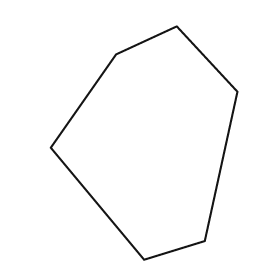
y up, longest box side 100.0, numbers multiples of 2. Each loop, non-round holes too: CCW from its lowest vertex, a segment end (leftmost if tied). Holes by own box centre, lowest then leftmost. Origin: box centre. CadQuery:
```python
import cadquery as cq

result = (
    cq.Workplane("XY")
    .moveTo(0.0, -50.0)
    .lineTo(26.0, -42.0)
    .lineTo(40.0, 22.0)
    .lineTo(14.0, 50.0)
    .lineTo(-12.0, 38.0)
    .lineTo(-40.0, -2.0)
    .close()
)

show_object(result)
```